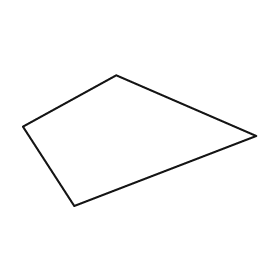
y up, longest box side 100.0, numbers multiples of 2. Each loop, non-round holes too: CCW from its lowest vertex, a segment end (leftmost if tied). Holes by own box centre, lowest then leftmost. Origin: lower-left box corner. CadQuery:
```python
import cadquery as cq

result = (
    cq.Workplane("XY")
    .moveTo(22.0, 0.0)
    .lineTo(100.0, 30.0)
    .lineTo(40.0, 56.0)
    .lineTo(0.0, 34.0)
    .close()
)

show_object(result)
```